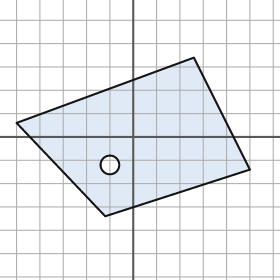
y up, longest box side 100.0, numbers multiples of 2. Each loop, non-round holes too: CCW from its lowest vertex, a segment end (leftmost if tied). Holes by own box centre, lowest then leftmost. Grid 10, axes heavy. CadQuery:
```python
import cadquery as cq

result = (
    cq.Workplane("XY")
    .moveTo(-12.0, -34.0)
    .lineTo(50.0, -14.0)
    .lineTo(26.0, 34.0)
    .lineTo(-50.0, 6.0)
    .close()
    .moveTo(-10.0, -12.0)
    .circle(4.0)
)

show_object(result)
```